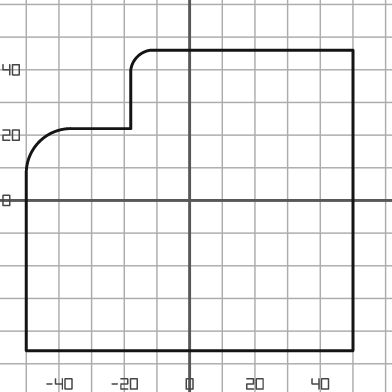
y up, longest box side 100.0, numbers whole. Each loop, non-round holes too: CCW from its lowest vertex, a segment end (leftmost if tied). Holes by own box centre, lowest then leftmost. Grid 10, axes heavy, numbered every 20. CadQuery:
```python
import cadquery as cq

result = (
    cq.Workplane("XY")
    .moveTo(-50.0, -46.0)
    .lineTo(50.0, -46.0)
    .lineTo(50.0, 46.0)
    .lineTo(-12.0, 46.0)
    .threePointArc((-16.0, 44.0), (-18.0, 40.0))
    .lineTo(-18.0, 22.0)
    .lineTo(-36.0, 22.0)
    .threePointArc((-46.0, 18.0), (-50.0, 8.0))
    .close()
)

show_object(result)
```